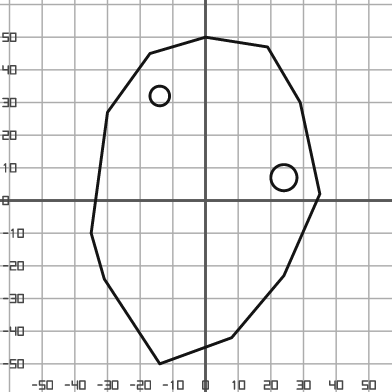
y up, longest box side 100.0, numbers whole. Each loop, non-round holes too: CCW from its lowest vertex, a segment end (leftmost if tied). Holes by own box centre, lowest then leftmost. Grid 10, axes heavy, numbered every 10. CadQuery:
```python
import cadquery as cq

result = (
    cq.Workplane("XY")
    .moveTo(-14.0, -50.0)
    .lineTo(8.0, -42.0)
    .lineTo(24.0, -23.0)
    .lineTo(35.0, 2.0)
    .lineTo(29.0, 30.0)
    .lineTo(19.0, 47.0)
    .lineTo(0.0, 50.0)
    .lineTo(-17.0, 45.0)
    .lineTo(-30.0, 27.0)
    .lineTo(-35.0, -10.0)
    .lineTo(-31.0, -24.0)
    .close()
    .moveTo(24.0, 7.0)
    .circle(4.0)
    .moveTo(-14.0, 32.0)
    .circle(3.0)
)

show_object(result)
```